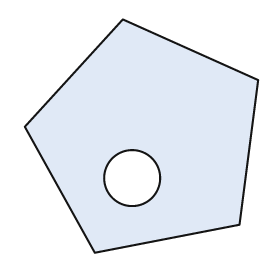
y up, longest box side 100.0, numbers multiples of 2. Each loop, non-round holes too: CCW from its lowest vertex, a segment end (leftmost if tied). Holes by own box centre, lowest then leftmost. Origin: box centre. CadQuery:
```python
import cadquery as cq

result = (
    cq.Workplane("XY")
    .moveTo(-20.0, -50.0)
    .lineTo(42.0, -38.0)
    .lineTo(50.0, 24.0)
    .lineTo(-8.0, 50.0)
    .lineTo(-50.0, 4.0)
    .close()
    .moveTo(-4.0, -18.0)
    .circle(12.0)
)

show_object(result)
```